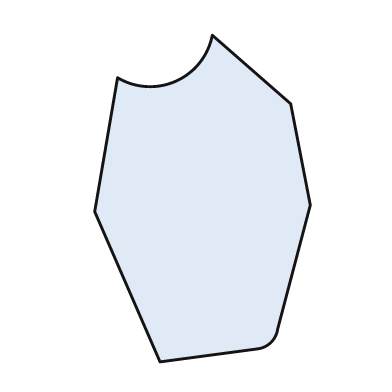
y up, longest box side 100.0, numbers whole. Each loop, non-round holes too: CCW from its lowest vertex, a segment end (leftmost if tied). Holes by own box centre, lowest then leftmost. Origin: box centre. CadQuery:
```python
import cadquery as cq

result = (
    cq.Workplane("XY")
    .moveTo(-13.0, -50.0)
    .lineTo(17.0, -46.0)
    .threePointArc((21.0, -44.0), (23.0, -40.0))
    .lineTo(33.0, -2.0)
    .lineTo(27.0, 29.0)
    .lineTo(3.0, 50.0)
    .threePointArc((-8.0, 36.0), (-26.0, 37.0))
    .lineTo(-33.0, -4.0)
    .close()
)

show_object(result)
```